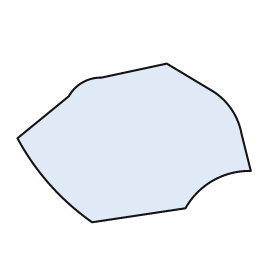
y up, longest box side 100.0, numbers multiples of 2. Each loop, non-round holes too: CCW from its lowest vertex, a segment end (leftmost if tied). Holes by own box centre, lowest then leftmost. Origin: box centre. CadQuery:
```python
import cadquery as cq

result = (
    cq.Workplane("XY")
    .moveTo(-18.0, -34.0)
    .lineTo(22.0, -28.0)
    .threePointArc((34.0, -16.0), (50.0, -12.0))
    .lineTo(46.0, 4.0)
    .threePointArc((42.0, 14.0), (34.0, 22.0))
    .lineTo(14.0, 34.0)
    .lineTo(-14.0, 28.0)
    .threePointArc((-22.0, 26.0), (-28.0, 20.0))
    .lineTo(-50.0, 2.0)
    .threePointArc((-36.0, -18.0), (-18.0, -34.0))
    .close()
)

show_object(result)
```